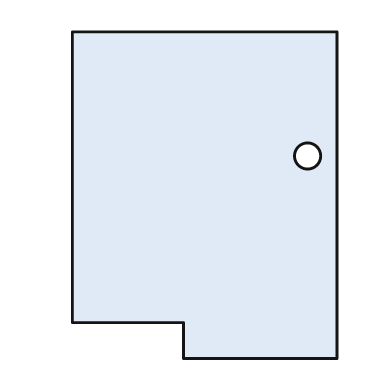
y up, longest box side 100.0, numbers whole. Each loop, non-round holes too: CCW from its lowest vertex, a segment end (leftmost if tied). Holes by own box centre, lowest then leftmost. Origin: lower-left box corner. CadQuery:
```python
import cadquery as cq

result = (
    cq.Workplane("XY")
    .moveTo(34.0, 0.0)
    .lineTo(81.0, 0.0)
    .lineTo(81.0, 100.0)
    .lineTo(0.0, 100.0)
    .lineTo(0.0, 11.0)
    .lineTo(34.0, 11.0)
    .close()
    .moveTo(72.0, 62.0)
    .circle(4.0)
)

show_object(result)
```